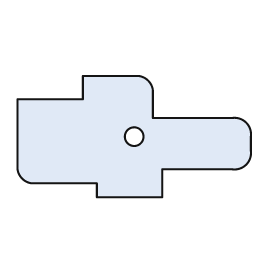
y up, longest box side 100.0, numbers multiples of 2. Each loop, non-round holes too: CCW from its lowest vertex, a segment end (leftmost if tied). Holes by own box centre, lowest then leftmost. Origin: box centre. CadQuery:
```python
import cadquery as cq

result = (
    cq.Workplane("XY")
    .moveTo(-16.0, -26.0)
    .lineTo(12.0, -26.0)
    .lineTo(12.0, -14.0)
    .lineTo(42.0, -14.0)
    .threePointArc((48.0, -12.0), (50.0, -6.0))
    .lineTo(50.0, 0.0)
    .threePointArc((48.0, 6.0), (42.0, 8.0))
    .lineTo(8.0, 8.0)
    .lineTo(8.0, 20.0)
    .threePointArc((6.0, 24.0), (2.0, 26.0))
    .lineTo(-22.0, 26.0)
    .lineTo(-22.0, 16.0)
    .lineTo(-50.0, 16.0)
    .lineTo(-50.0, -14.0)
    .threePointArc((-48.0, -18.0), (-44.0, -20.0))
    .lineTo(-16.0, -20.0)
    .close()
    .moveTo(0.0, 0.0)
    .circle(4.0)
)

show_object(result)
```